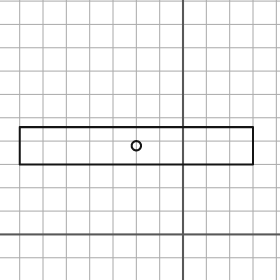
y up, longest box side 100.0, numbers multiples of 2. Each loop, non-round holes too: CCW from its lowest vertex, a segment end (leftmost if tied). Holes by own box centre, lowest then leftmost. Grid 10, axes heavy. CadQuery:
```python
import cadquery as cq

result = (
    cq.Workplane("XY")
    .moveTo(-70.0, 30.0)
    .lineTo(30.0, 30.0)
    .lineTo(30.0, 46.0)
    .lineTo(-70.0, 46.0)
    .close()
    .moveTo(-20.0, 38.0)
    .circle(2.0)
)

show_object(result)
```